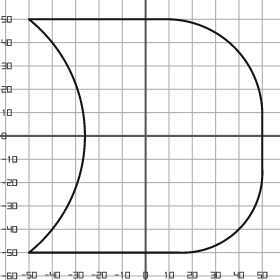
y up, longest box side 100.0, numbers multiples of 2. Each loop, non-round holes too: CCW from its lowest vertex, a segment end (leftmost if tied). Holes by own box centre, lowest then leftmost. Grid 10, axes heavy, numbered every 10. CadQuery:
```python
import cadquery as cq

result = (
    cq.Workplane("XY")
    .moveTo(-50.0, -50.0)
    .lineTo(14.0, -50.0)
    .threePointArc((40.0, -40.0), (50.0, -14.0))
    .lineTo(50.0, 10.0)
    .threePointArc((38.0, 38.0), (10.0, 50.0))
    .lineTo(-50.0, 50.0)
    .threePointArc((-26.0, 0.0), (-50.0, -50.0))
    .close()
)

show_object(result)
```